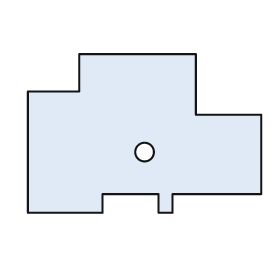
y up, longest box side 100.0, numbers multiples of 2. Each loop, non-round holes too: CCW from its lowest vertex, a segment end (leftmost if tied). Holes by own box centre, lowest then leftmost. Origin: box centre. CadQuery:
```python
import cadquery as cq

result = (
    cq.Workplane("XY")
    .moveTo(-50.0, -34.0)
    .lineTo(-18.0, -34.0)
    .lineTo(-18.0, -26.0)
    .lineTo(6.0, -26.0)
    .lineTo(6.0, -34.0)
    .lineTo(12.0, -34.0)
    .lineTo(12.0, -26.0)
    .lineTo(50.0, -26.0)
    .lineTo(50.0, 8.0)
    .lineTo(22.0, 8.0)
    .lineTo(22.0, 34.0)
    .lineTo(-28.0, 34.0)
    .lineTo(-28.0, 18.0)
    .lineTo(-50.0, 18.0)
    .close()
    .moveTo(0.0, -8.0)
    .circle(4.0)
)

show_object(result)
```